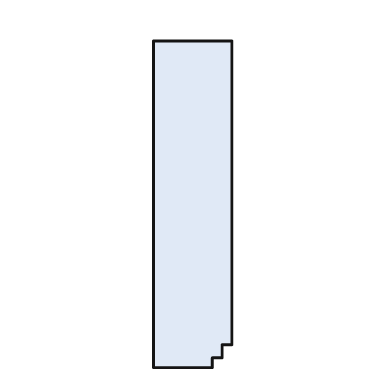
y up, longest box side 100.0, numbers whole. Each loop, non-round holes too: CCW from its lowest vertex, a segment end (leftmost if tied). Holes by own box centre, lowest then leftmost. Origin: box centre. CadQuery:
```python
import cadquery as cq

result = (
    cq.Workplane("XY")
    .moveTo(-12.0, -50.0)
    .lineTo(6.0, -50.0)
    .lineTo(6.0, -47.0)
    .lineTo(9.0, -47.0)
    .lineTo(9.0, -43.0)
    .lineTo(12.0, -43.0)
    .lineTo(12.0, 50.0)
    .lineTo(-12.0, 50.0)
    .close()
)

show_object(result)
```